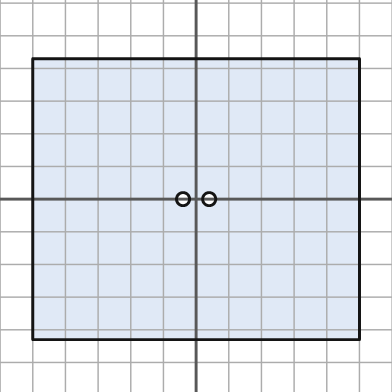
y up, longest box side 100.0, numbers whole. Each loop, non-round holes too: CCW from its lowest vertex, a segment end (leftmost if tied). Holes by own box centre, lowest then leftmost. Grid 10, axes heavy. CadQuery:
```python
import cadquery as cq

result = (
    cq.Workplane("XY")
    .moveTo(-50.0, -43.0)
    .lineTo(50.0, -43.0)
    .lineTo(50.0, 43.0)
    .lineTo(-50.0, 43.0)
    .close()
    .moveTo(-4.0, 0.0)
    .circle(2.0)
    .moveTo(4.0, 0.0)
    .circle(2.0)
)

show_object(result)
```